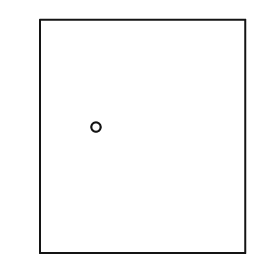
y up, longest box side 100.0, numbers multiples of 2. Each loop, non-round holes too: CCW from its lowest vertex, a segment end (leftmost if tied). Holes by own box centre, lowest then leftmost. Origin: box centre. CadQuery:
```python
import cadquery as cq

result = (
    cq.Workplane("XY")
    .moveTo(-44.0, -50.0)
    .lineTo(44.0, -50.0)
    .lineTo(44.0, 50.0)
    .lineTo(-44.0, 50.0)
    .close()
    .moveTo(-20.0, 4.0)
    .circle(2.0)
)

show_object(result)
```